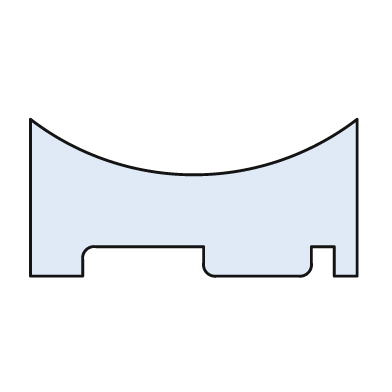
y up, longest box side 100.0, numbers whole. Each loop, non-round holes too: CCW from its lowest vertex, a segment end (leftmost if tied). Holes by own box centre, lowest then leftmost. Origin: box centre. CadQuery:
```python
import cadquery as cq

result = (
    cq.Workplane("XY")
    .moveTo(-50.0, -24.0)
    .lineTo(-34.0, -24.0)
    .lineTo(-34.0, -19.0)
    .threePointArc((-33.0, -16.0), (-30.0, -15.0))
    .lineTo(3.0, -15.0)
    .lineTo(3.0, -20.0)
    .threePointArc((4.0, -23.0), (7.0, -24.0))
    .lineTo(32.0, -24.0)
    .threePointArc((35.0, -23.0), (36.0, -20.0))
    .lineTo(36.0, -15.0)
    .lineTo(43.0, -15.0)
    .lineTo(43.0, -24.0)
    .lineTo(50.0, -24.0)
    .lineTo(50.0, 24.0)
    .threePointArc((0.0, 7.0), (-50.0, 24.0))
    .close()
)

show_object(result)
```